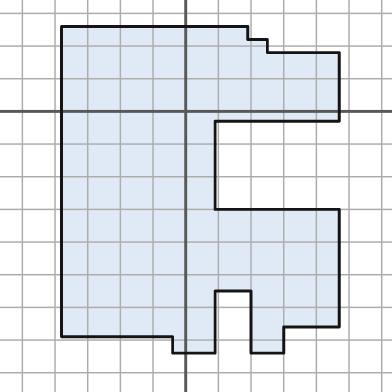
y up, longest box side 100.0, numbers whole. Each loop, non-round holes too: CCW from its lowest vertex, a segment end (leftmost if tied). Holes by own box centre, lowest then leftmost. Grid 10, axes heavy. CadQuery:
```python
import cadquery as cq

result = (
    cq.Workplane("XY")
    .moveTo(-4.0, -74.0)
    .lineTo(9.0, -74.0)
    .lineTo(9.0, -55.0)
    .lineTo(20.0, -55.0)
    .lineTo(20.0, -74.0)
    .lineTo(30.0, -74.0)
    .lineTo(30.0, -66.0)
    .lineTo(47.0, -66.0)
    .lineTo(47.0, -30.0)
    .lineTo(9.0, -30.0)
    .lineTo(9.0, -3.0)
    .lineTo(47.0, -3.0)
    .lineTo(47.0, 18.0)
    .lineTo(25.0, 18.0)
    .lineTo(25.0, 22.0)
    .lineTo(19.0, 22.0)
    .lineTo(19.0, 26.0)
    .lineTo(-38.0, 26.0)
    .lineTo(-38.0, -69.0)
    .lineTo(-4.0, -69.0)
    .close()
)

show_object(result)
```